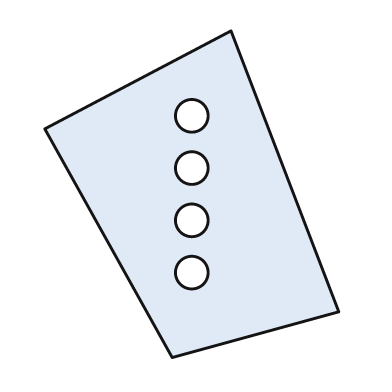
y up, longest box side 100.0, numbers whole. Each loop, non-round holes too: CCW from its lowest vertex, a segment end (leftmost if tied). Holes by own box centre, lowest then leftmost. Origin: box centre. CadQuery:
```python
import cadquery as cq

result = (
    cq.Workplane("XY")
    .moveTo(-6.0, -50.0)
    .lineTo(45.0, -36.0)
    .lineTo(12.0, 50.0)
    .lineTo(-45.0, 20.0)
    .close()
    .moveTo(0.0, -24.0)
    .circle(5.0)
    .moveTo(0.0, -8.0)
    .circle(5.0)
    .moveTo(0.0, 8.0)
    .circle(5.0)
    .moveTo(0.0, 24.0)
    .circle(5.0)
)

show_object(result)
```